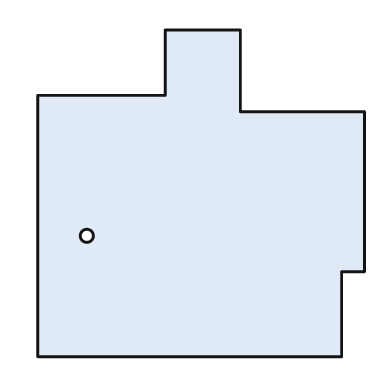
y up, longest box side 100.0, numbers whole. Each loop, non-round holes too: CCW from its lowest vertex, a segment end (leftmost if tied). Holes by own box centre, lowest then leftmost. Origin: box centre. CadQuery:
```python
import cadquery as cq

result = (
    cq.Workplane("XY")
    .moveTo(-50.0, -50.0)
    .lineTo(43.0, -50.0)
    .lineTo(43.0, -24.0)
    .lineTo(50.0, -24.0)
    .lineTo(50.0, 25.0)
    .lineTo(12.0, 25.0)
    .lineTo(12.0, 50.0)
    .lineTo(-11.0, 50.0)
    .lineTo(-11.0, 30.0)
    .lineTo(-50.0, 30.0)
    .close()
    .moveTo(-35.0, -13.0)
    .circle(2.0)
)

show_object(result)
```